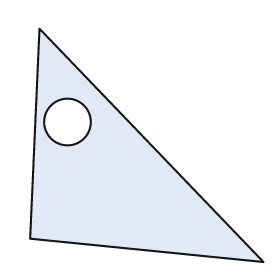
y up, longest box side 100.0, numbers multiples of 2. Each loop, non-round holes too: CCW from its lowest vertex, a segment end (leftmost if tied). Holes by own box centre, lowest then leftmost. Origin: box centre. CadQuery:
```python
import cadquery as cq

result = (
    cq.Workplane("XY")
    .moveTo(50.0, -50.0)
    .lineTo(-46.0, 50.0)
    .lineTo(-50.0, -40.0)
    .close()
    .moveTo(-34.0, 10.0)
    .circle(10.0)
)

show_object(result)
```